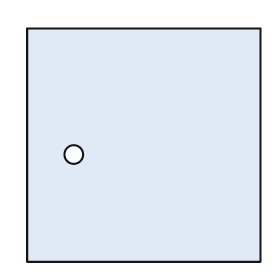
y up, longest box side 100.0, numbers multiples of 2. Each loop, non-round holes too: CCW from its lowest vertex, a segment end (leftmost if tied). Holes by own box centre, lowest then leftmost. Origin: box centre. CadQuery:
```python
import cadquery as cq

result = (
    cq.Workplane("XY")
    .moveTo(-50.0, -50.0)
    .lineTo(50.0, -50.0)
    .lineTo(50.0, 50.0)
    .lineTo(-50.0, 50.0)
    .close()
    .moveTo(-30.0, -4.0)
    .circle(4.0)
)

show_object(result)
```